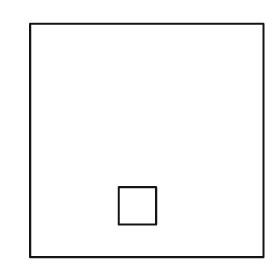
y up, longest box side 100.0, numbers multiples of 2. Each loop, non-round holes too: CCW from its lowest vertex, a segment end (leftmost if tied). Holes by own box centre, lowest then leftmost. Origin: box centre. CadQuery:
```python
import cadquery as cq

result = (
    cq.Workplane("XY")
    .moveTo(-50.0, -50.0)
    .lineTo(50.0, -50.0)
    .lineTo(50.0, 50.0)
    .lineTo(-50.0, 50.0)
    .close()
    .moveTo(-12.0, -36.0)
    .lineTo(4.0, -36.0)
    .lineTo(4.0, -20.0)
    .lineTo(-12.0, -20.0)
    .close()
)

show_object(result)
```